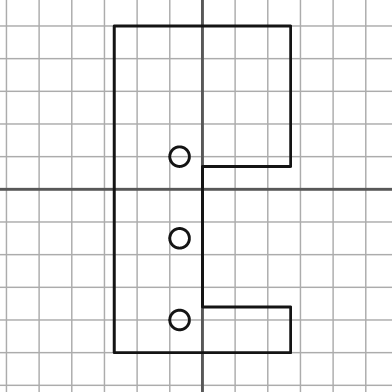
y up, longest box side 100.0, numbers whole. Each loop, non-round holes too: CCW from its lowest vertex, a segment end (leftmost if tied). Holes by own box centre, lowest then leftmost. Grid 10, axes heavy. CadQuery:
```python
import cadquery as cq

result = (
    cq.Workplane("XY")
    .moveTo(-27.0, -50.0)
    .lineTo(27.0, -50.0)
    .lineTo(27.0, -36.0)
    .lineTo(0.0, -36.0)
    .lineTo(0.0, 7.0)
    .lineTo(27.0, 7.0)
    .lineTo(27.0, 50.0)
    .lineTo(-27.0, 50.0)
    .close()
    .moveTo(-7.0, -40.0)
    .circle(3.0)
    .moveTo(-7.0, -15.0)
    .circle(3.0)
    .moveTo(-7.0, 10.0)
    .circle(3.0)
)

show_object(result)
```